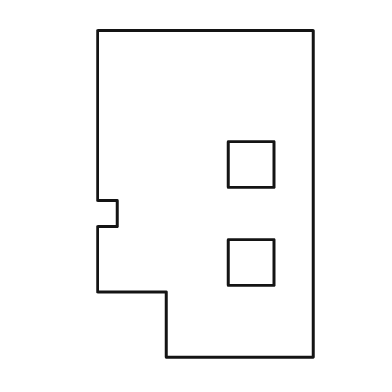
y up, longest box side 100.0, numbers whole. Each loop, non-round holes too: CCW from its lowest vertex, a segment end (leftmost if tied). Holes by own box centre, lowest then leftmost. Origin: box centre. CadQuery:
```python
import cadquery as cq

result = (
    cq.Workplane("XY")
    .moveTo(-12.0, -50.0)
    .lineTo(33.0, -50.0)
    .lineTo(33.0, 50.0)
    .lineTo(-33.0, 50.0)
    .lineTo(-33.0, -2.0)
    .lineTo(-27.0, -2.0)
    .lineTo(-27.0, -10.0)
    .lineTo(-33.0, -10.0)
    .lineTo(-33.0, -30.0)
    .lineTo(-12.0, -30.0)
    .close()
    .moveTo(7.0, -28.0)
    .lineTo(21.0, -28.0)
    .lineTo(21.0, -14.0)
    .lineTo(7.0, -14.0)
    .close()
    .moveTo(7.0, 2.0)
    .lineTo(21.0, 2.0)
    .lineTo(21.0, 16.0)
    .lineTo(7.0, 16.0)
    .close()
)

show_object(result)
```